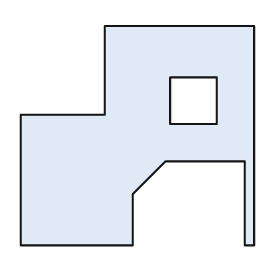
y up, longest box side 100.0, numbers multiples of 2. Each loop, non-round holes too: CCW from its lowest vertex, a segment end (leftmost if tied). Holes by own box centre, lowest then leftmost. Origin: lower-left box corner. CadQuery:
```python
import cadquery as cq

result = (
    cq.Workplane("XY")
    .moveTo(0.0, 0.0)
    .lineTo(48.0, 0.0)
    .lineTo(48.0, 22.0)
    .lineTo(62.0, 36.0)
    .lineTo(96.0, 36.0)
    .lineTo(96.0, 0.0)
    .lineTo(100.0, 0.0)
    .lineTo(100.0, 94.0)
    .lineTo(36.0, 94.0)
    .lineTo(36.0, 56.0)
    .lineTo(0.0, 56.0)
    .close()
    .moveTo(64.0, 52.0)
    .lineTo(84.0, 52.0)
    .lineTo(84.0, 72.0)
    .lineTo(64.0, 72.0)
    .close()
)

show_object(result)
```